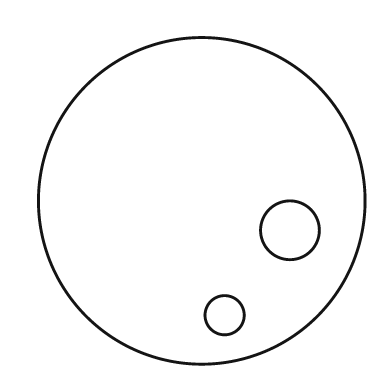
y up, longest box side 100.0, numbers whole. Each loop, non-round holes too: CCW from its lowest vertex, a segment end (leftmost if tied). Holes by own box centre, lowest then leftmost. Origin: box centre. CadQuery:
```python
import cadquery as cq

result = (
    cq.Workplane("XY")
    .moveTo(0.0, 0.0)
    .circle(50.0)
    .moveTo(7.0, -35.0)
    .circle(6.0)
    .moveTo(27.0, -9.0)
    .circle(9.0)
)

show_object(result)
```